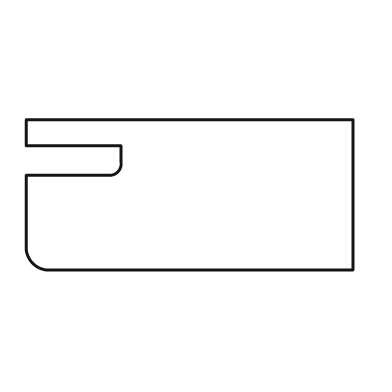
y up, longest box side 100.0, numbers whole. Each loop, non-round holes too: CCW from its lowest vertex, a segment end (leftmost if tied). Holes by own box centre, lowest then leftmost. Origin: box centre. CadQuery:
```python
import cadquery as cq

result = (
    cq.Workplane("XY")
    .moveTo(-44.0, -23.0)
    .lineTo(50.0, -23.0)
    .lineTo(50.0, 23.0)
    .lineTo(-50.0, 23.0)
    .lineTo(-50.0, 15.0)
    .lineTo(-21.0, 15.0)
    .lineTo(-21.0, 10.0)
    .threePointArc((-22.0, 7.0), (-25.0, 6.0))
    .lineTo(-50.0, 6.0)
    .lineTo(-50.0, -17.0)
    .threePointArc((-48.0, -21.0), (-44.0, -23.0))
    .close()
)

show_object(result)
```